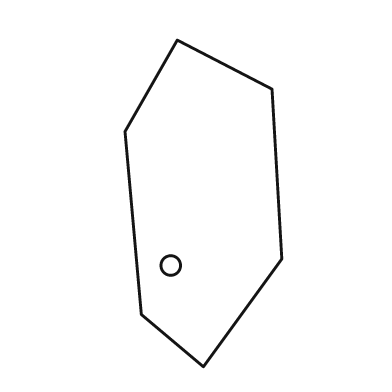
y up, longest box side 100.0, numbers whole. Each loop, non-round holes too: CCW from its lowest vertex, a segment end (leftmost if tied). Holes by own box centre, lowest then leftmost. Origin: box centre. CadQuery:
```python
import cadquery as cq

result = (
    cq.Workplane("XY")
    .moveTo(0.0, -50.0)
    .lineTo(24.0, -17.0)
    .lineTo(21.0, 35.0)
    .lineTo(-8.0, 50.0)
    .lineTo(-24.0, 22.0)
    .lineTo(-19.0, -34.0)
    .close()
    .moveTo(-10.0, -19.0)
    .circle(3.0)
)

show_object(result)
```